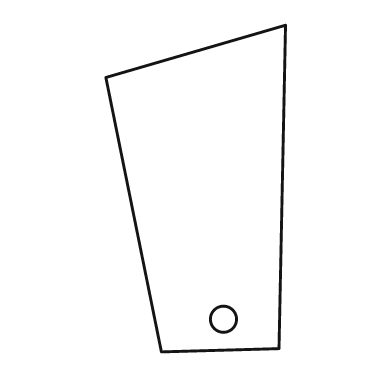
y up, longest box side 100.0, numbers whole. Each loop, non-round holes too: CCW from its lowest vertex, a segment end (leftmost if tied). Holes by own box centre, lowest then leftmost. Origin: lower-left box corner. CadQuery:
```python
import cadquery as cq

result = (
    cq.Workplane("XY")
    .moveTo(17.0, 0.0)
    .lineTo(53.0, 1.0)
    .lineTo(55.0, 100.0)
    .lineTo(0.0, 84.0)
    .close()
    .moveTo(36.0, 10.0)
    .circle(4.0)
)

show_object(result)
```